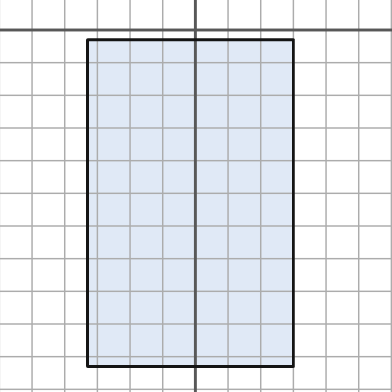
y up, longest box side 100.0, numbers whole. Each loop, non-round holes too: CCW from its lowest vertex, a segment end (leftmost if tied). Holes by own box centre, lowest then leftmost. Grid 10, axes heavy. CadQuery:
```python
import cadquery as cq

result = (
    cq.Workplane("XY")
    .moveTo(-33.0, -103.0)
    .lineTo(30.0, -103.0)
    .lineTo(30.0, -3.0)
    .lineTo(-33.0, -3.0)
    .close()
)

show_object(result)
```